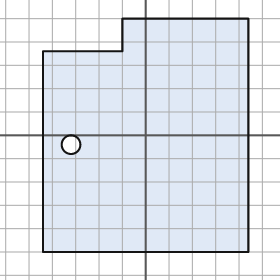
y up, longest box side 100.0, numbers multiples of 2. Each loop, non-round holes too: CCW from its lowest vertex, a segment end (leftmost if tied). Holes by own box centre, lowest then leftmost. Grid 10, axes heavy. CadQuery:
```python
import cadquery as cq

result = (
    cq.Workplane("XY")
    .moveTo(-44.0, -50.0)
    .lineTo(44.0, -50.0)
    .lineTo(44.0, 50.0)
    .lineTo(-10.0, 50.0)
    .lineTo(-10.0, 36.0)
    .lineTo(-44.0, 36.0)
    .close()
    .moveTo(-32.0, -4.0)
    .circle(4.0)
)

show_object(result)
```